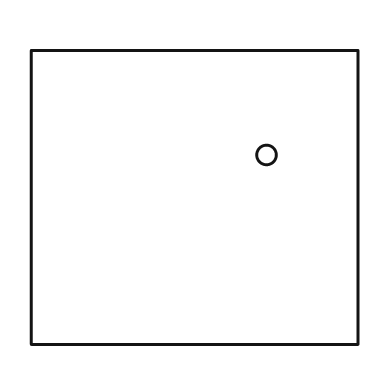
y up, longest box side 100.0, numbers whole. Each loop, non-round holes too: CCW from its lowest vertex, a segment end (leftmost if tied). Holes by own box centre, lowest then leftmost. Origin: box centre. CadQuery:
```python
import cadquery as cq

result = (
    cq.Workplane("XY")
    .moveTo(-50.0, -45.0)
    .lineTo(50.0, -45.0)
    .lineTo(50.0, 45.0)
    .lineTo(-50.0, 45.0)
    .close()
    .moveTo(22.0, 13.0)
    .circle(3.0)
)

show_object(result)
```